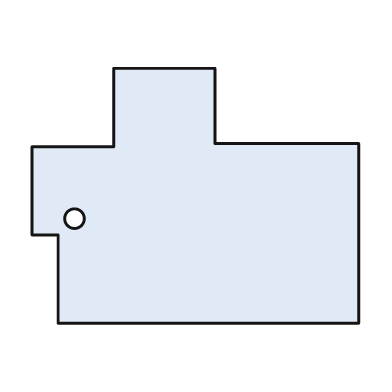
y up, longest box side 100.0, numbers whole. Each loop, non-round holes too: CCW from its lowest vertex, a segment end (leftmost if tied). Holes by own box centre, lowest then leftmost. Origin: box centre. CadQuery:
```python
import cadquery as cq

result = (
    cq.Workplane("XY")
    .moveTo(-42.0, -39.0)
    .lineTo(50.0, -39.0)
    .lineTo(50.0, 16.0)
    .lineTo(6.0, 16.0)
    .lineTo(6.0, 39.0)
    .lineTo(-25.0, 39.0)
    .lineTo(-25.0, 15.0)
    .lineTo(-50.0, 15.0)
    .lineTo(-50.0, -12.0)
    .lineTo(-42.0, -12.0)
    .close()
    .moveTo(-37.0, -7.0)
    .circle(3.0)
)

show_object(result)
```